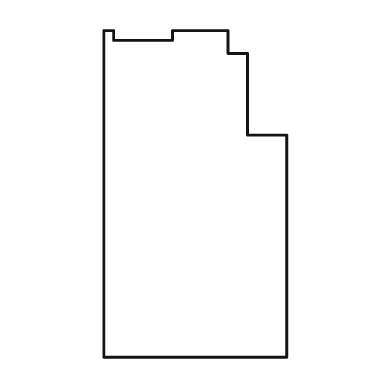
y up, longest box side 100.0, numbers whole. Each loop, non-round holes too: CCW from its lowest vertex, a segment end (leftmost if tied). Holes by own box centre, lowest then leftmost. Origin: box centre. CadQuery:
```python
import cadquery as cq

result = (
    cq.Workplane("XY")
    .moveTo(-28.0, -50.0)
    .lineTo(28.0, -50.0)
    .lineTo(28.0, 18.0)
    .lineTo(16.0, 18.0)
    .lineTo(16.0, 43.0)
    .lineTo(10.0, 43.0)
    .lineTo(10.0, 50.0)
    .lineTo(-7.0, 50.0)
    .lineTo(-7.0, 47.0)
    .lineTo(-25.0, 47.0)
    .lineTo(-25.0, 50.0)
    .lineTo(-28.0, 50.0)
    .close()
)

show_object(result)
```